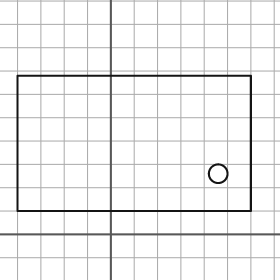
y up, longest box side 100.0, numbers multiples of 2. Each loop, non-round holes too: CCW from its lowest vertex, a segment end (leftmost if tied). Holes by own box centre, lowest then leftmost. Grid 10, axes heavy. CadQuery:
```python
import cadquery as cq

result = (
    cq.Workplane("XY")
    .moveTo(-40.0, 10.0)
    .lineTo(60.0, 10.0)
    .lineTo(60.0, 68.0)
    .lineTo(-40.0, 68.0)
    .close()
    .moveTo(46.0, 26.0)
    .circle(4.0)
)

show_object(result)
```